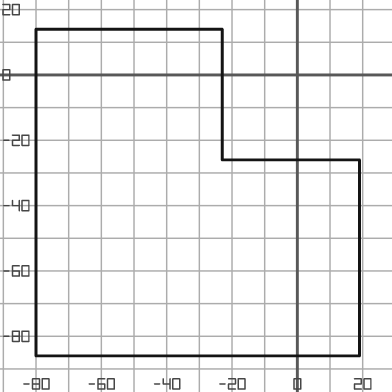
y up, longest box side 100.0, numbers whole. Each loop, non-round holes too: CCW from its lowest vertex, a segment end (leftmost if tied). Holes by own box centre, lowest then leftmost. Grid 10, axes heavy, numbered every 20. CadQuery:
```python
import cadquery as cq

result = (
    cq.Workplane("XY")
    .moveTo(-80.0, -86.0)
    .lineTo(19.0, -86.0)
    .lineTo(19.0, -26.0)
    .lineTo(-23.0, -26.0)
    .lineTo(-23.0, 14.0)
    .lineTo(-80.0, 14.0)
    .close()
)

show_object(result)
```